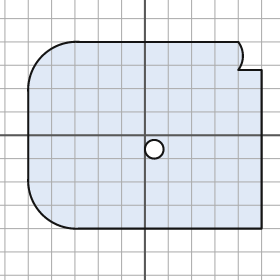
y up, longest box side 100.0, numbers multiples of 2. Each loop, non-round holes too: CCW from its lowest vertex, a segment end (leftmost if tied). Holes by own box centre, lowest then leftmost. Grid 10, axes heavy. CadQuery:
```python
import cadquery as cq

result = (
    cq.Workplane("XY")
    .moveTo(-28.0, -40.0)
    .lineTo(50.0, -40.0)
    .lineTo(50.0, 28.0)
    .lineTo(40.0, 28.0)
    .threePointArc((42.0, 34.0), (40.0, 40.0))
    .lineTo(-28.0, 40.0)
    .threePointArc((-44.0, 34.0), (-50.0, 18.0))
    .lineTo(-50.0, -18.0)
    .threePointArc((-44.0, -34.0), (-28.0, -40.0))
    .close()
    .moveTo(4.0, -6.0)
    .circle(4.0)
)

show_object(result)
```